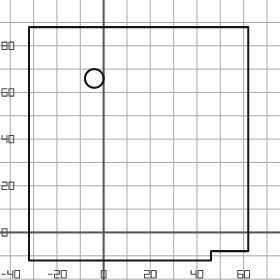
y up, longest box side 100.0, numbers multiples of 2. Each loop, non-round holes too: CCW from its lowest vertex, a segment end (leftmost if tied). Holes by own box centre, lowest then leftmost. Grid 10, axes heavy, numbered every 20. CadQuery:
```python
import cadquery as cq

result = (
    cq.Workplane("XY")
    .moveTo(-32.0, -12.0)
    .lineTo(46.0, -12.0)
    .lineTo(46.0, -8.0)
    .lineTo(62.0, -8.0)
    .lineTo(62.0, 88.0)
    .lineTo(-32.0, 88.0)
    .close()
    .moveTo(-4.0, 66.0)
    .circle(4.0)
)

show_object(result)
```